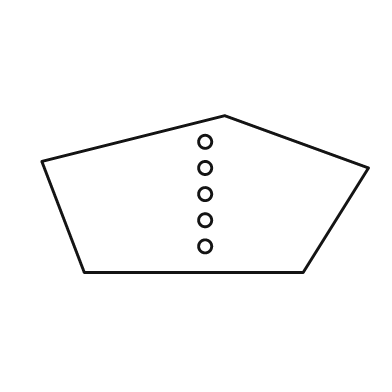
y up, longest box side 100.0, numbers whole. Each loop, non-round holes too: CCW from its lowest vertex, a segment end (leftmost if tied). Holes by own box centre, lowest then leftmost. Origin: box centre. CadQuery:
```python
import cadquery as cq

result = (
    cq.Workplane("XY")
    .moveTo(-37.0, -24.0)
    .lineTo(30.0, -24.0)
    .lineTo(50.0, 8.0)
    .lineTo(6.0, 24.0)
    .lineTo(-50.0, 10.0)
    .close()
    .moveTo(0.0, -16.0)
    .circle(2.0)
    .moveTo(0.0, -8.0)
    .circle(2.0)
    .moveTo(0.0, 0.0)
    .circle(2.0)
    .moveTo(0.0, 8.0)
    .circle(2.0)
    .moveTo(0.0, 16.0)
    .circle(2.0)
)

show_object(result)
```